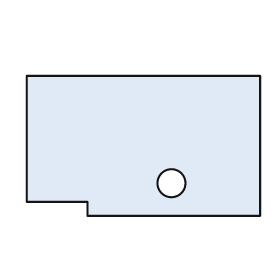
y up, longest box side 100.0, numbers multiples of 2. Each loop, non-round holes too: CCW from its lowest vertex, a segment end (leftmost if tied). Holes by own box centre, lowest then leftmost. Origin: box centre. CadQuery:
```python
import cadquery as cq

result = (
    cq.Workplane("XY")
    .moveTo(-24.0, -30.0)
    .lineTo(50.0, -30.0)
    .lineTo(50.0, 30.0)
    .lineTo(-50.0, 30.0)
    .lineTo(-50.0, -24.0)
    .lineTo(-24.0, -24.0)
    .close()
    .moveTo(12.0, -16.0)
    .circle(6.0)
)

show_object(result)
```